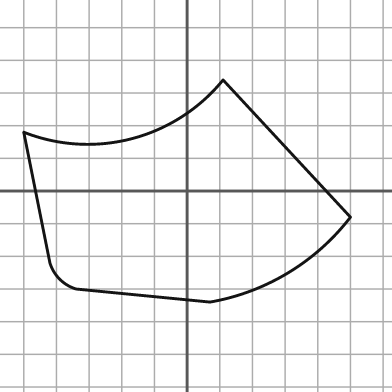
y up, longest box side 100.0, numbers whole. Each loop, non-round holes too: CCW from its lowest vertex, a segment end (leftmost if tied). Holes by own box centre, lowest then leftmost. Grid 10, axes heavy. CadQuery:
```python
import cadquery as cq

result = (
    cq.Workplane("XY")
    .moveTo(7.0, -34.0)
    .threePointArc((31.0, -25.0), (50.0, -8.0))
    .lineTo(11.0, 34.0)
    .threePointArc((-17.0, 16.0), (-50.0, 18.0))
    .lineTo(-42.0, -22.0)
    .threePointArc((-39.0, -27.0), (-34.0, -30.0))
    .close()
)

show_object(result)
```